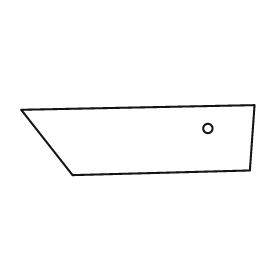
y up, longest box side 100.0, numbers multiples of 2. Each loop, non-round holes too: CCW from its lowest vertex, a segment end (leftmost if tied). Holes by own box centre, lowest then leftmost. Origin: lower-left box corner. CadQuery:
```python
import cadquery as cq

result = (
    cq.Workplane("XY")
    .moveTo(22.0, 0.0)
    .lineTo(98.0, 2.0)
    .lineTo(100.0, 30.0)
    .lineTo(0.0, 28.0)
    .close()
    .moveTo(80.0, 20.0)
    .circle(2.0)
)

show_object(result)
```